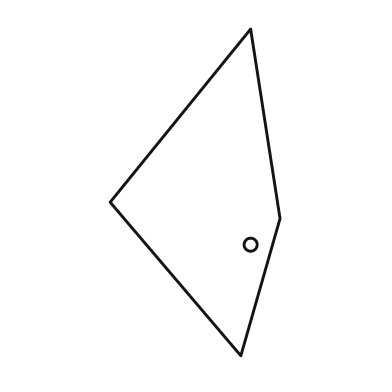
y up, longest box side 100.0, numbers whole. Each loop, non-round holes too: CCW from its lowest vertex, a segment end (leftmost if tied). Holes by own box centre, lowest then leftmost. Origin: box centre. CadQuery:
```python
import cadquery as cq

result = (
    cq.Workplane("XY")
    .moveTo(14.0, -50.0)
    .lineTo(26.0, -8.0)
    .lineTo(17.0, 50.0)
    .lineTo(-26.0, -3.0)
    .close()
    .moveTo(17.0, -16.0)
    .circle(2.0)
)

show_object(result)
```